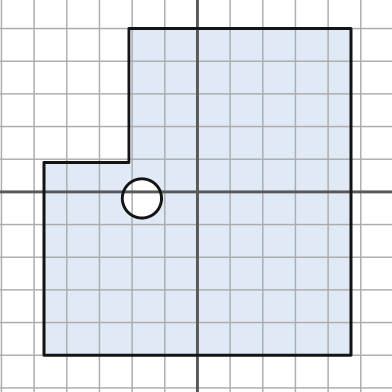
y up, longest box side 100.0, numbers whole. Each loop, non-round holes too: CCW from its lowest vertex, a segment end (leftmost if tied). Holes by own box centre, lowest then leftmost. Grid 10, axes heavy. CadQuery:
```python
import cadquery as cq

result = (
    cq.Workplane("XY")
    .moveTo(-47.0, -50.0)
    .lineTo(47.0, -50.0)
    .lineTo(47.0, 50.0)
    .lineTo(-21.0, 50.0)
    .lineTo(-21.0, 9.0)
    .lineTo(-47.0, 9.0)
    .close()
    .moveTo(-17.0, -2.0)
    .circle(6.0)
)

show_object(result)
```